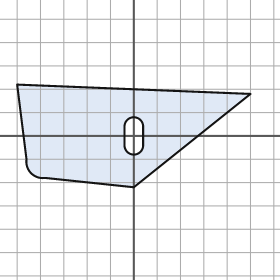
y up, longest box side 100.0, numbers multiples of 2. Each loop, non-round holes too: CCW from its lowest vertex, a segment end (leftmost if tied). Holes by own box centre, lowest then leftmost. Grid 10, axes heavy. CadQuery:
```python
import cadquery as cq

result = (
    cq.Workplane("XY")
    .moveTo(0.0, -22.0)
    .lineTo(50.0, 18.0)
    .lineTo(-50.0, 22.0)
    .lineTo(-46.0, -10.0)
    .threePointArc((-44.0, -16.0), (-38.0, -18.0))
    .close()
    .moveTo(-4.0, -4.0)
    .threePointArc((0.0, -8.0), (4.0, -4.0))
    .lineTo(4.0, 4.0)
    .threePointArc((0.0, 8.0), (-4.0, 4.0))
    .close()
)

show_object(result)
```